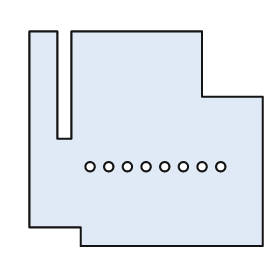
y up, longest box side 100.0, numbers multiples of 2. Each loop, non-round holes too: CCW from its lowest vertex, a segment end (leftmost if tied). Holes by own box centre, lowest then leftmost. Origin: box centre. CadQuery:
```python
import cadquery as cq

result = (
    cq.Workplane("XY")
    .moveTo(-28.0, -46.0)
    .lineTo(50.0, -46.0)
    .lineTo(50.0, 18.0)
    .lineTo(24.0, 18.0)
    .lineTo(24.0, 46.0)
    .lineTo(-32.0, 46.0)
    .lineTo(-32.0, 0.0)
    .lineTo(-38.0, 0.0)
    .lineTo(-38.0, 46.0)
    .lineTo(-50.0, 46.0)
    .lineTo(-50.0, -38.0)
    .lineTo(-28.0, -38.0)
    .close()
    .moveTo(-24.0, -12.0)
    .circle(2.0)
    .moveTo(-16.0, -12.0)
    .circle(2.0)
    .moveTo(-8.0, -12.0)
    .circle(2.0)
    .moveTo(0.0, -12.0)
    .circle(2.0)
    .moveTo(8.0, -12.0)
    .circle(2.0)
    .moveTo(16.0, -12.0)
    .circle(2.0)
    .moveTo(24.0, -12.0)
    .circle(2.0)
    .moveTo(32.0, -12.0)
    .circle(2.0)
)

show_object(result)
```